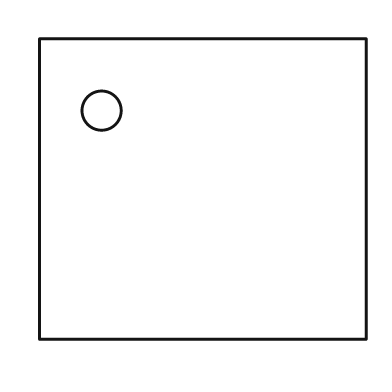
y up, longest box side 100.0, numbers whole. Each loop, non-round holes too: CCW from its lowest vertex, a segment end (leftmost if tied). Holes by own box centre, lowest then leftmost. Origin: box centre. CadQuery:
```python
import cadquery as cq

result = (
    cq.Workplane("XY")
    .moveTo(-50.0, -46.0)
    .lineTo(50.0, -46.0)
    .lineTo(50.0, 46.0)
    .lineTo(-50.0, 46.0)
    .close()
    .moveTo(-31.0, 24.0)
    .circle(6.0)
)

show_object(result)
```